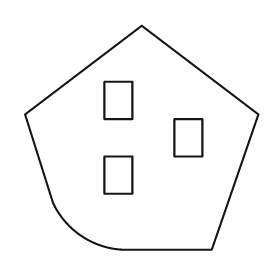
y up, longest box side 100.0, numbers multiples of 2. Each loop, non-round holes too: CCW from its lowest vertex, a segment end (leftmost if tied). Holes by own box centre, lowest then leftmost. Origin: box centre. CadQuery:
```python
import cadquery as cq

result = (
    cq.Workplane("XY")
    .moveTo(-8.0, -48.0)
    .lineTo(30.0, -48.0)
    .lineTo(50.0, 10.0)
    .lineTo(0.0, 48.0)
    .lineTo(-50.0, 10.0)
    .lineTo(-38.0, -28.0)
    .threePointArc((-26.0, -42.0), (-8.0, -48.0))
    .close()
    .moveTo(-16.0, -24.0)
    .lineTo(-4.0, -24.0)
    .lineTo(-4.0, -8.0)
    .lineTo(-16.0, -8.0)
    .close()
    .moveTo(14.0, -8.0)
    .lineTo(26.0, -8.0)
    .lineTo(26.0, 8.0)
    .lineTo(14.0, 8.0)
    .close()
    .moveTo(-16.0, 8.0)
    .lineTo(-4.0, 8.0)
    .lineTo(-4.0, 24.0)
    .lineTo(-16.0, 24.0)
    .close()
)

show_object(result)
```